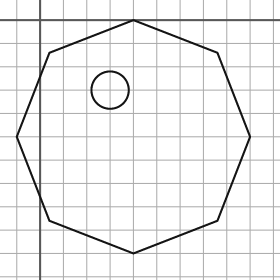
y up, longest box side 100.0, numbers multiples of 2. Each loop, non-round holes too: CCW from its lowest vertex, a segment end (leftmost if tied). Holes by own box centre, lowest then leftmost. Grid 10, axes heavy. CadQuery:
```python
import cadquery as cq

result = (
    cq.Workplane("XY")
    .moveTo(40.0, -100.0)
    .lineTo(76.0, -86.0)
    .lineTo(90.0, -50.0)
    .lineTo(76.0, -14.0)
    .lineTo(40.0, 0.0)
    .lineTo(4.0, -14.0)
    .lineTo(-10.0, -50.0)
    .lineTo(4.0, -86.0)
    .close()
    .moveTo(30.0, -30.0)
    .circle(8.0)
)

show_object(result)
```